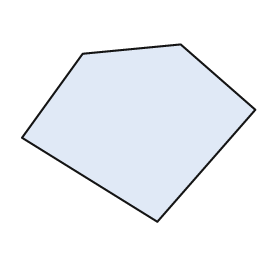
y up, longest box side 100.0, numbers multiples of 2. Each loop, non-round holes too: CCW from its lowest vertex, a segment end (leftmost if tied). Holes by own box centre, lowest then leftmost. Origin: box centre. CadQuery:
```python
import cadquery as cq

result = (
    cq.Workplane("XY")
    .moveTo(8.0, -38.0)
    .lineTo(50.0, 10.0)
    .lineTo(18.0, 38.0)
    .lineTo(-24.0, 34.0)
    .lineTo(-50.0, -2.0)
    .close()
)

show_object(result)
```